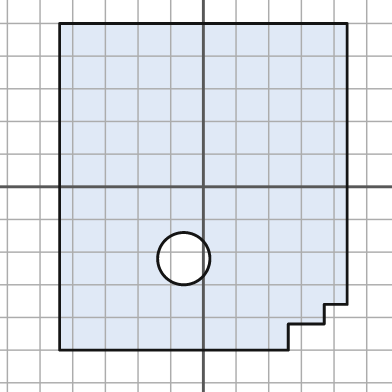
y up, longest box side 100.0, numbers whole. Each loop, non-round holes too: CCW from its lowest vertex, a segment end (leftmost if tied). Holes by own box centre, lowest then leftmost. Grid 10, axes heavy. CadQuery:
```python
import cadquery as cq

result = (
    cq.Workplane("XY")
    .moveTo(-44.0, -50.0)
    .lineTo(26.0, -50.0)
    .lineTo(26.0, -42.0)
    .lineTo(37.0, -42.0)
    .lineTo(37.0, -36.0)
    .lineTo(44.0, -36.0)
    .lineTo(44.0, 50.0)
    .lineTo(-44.0, 50.0)
    .close()
    .moveTo(-6.0, -22.0)
    .circle(8.0)
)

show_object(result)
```